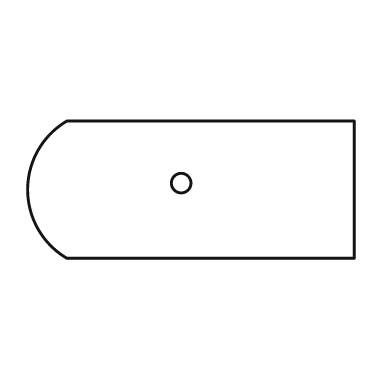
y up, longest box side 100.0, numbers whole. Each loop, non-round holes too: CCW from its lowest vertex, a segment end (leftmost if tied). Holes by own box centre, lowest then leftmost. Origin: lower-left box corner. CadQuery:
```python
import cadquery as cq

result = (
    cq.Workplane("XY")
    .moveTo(12.0, 0.0)
    .lineTo(100.0, 0.0)
    .lineTo(100.0, 42.0)
    .lineTo(12.0, 42.0)
    .threePointArc((0.0, 21.0), (12.0, 0.0))
    .close()
    .moveTo(47.0, 23.0)
    .circle(3.0)
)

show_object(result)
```